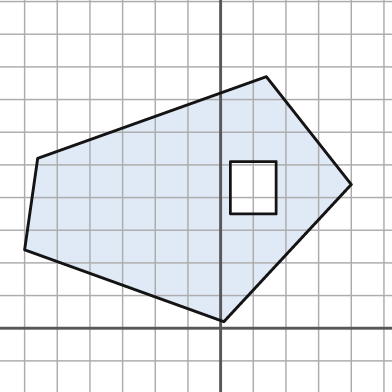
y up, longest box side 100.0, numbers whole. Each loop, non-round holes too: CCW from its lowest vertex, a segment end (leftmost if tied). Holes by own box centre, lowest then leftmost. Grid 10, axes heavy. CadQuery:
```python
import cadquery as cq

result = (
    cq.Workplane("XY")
    .moveTo(1.0, 2.0)
    .lineTo(40.0, 44.0)
    .lineTo(14.0, 77.0)
    .lineTo(-56.0, 52.0)
    .lineTo(-60.0, 24.0)
    .close()
    .moveTo(3.0, 35.0)
    .lineTo(17.0, 35.0)
    .lineTo(17.0, 51.0)
    .lineTo(3.0, 51.0)
    .close()
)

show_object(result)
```